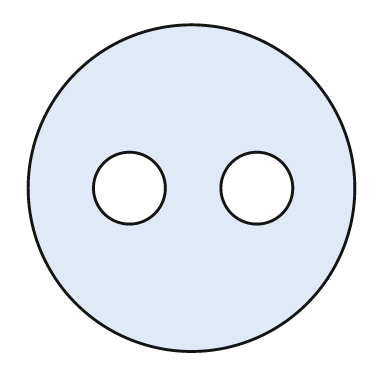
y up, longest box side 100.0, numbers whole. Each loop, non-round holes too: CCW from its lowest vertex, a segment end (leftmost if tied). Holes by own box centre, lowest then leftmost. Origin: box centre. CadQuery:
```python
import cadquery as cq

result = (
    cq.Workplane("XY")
    .moveTo(0.0, 0.0)
    .circle(50.0)
    .moveTo(-19.0, 0.0)
    .circle(11.0)
    .moveTo(20.0, 0.0)
    .circle(11.0)
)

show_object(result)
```